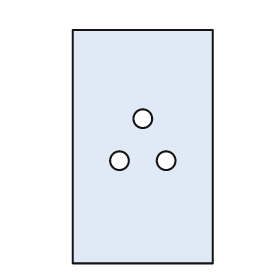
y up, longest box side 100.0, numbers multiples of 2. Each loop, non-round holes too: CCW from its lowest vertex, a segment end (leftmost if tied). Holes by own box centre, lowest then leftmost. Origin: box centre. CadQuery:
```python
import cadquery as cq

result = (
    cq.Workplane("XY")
    .moveTo(-30.0, -50.0)
    .lineTo(30.0, -50.0)
    .lineTo(30.0, 50.0)
    .lineTo(-30.0, 50.0)
    .close()
    .moveTo(-10.0, -6.0)
    .circle(4.0)
    .moveTo(10.0, -6.0)
    .circle(4.0)
    .moveTo(0.0, 12.0)
    .circle(4.0)
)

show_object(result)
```